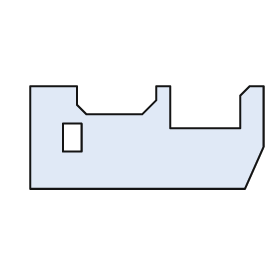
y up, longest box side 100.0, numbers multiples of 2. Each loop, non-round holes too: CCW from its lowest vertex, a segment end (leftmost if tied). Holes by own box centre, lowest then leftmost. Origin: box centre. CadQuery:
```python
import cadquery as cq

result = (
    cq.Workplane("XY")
    .moveTo(-50.0, -22.0)
    .lineTo(42.0, -22.0)
    .lineTo(50.0, -4.0)
    .lineTo(50.0, 22.0)
    .lineTo(44.0, 22.0)
    .lineTo(40.0, 18.0)
    .lineTo(40.0, 4.0)
    .lineTo(10.0, 4.0)
    .lineTo(10.0, 22.0)
    .lineTo(4.0, 22.0)
    .lineTo(4.0, 16.0)
    .lineTo(-2.0, 10.0)
    .lineTo(-26.0, 10.0)
    .lineTo(-30.0, 14.0)
    .lineTo(-30.0, 22.0)
    .lineTo(-50.0, 22.0)
    .close()
    .moveTo(-36.0, -6.0)
    .lineTo(-28.0, -6.0)
    .lineTo(-28.0, 6.0)
    .lineTo(-36.0, 6.0)
    .close()
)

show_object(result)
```